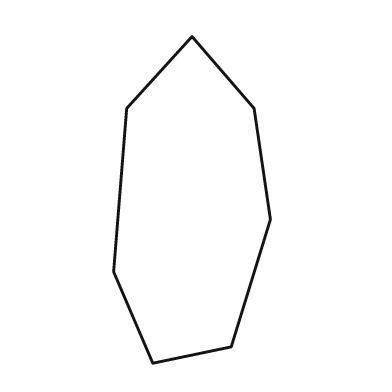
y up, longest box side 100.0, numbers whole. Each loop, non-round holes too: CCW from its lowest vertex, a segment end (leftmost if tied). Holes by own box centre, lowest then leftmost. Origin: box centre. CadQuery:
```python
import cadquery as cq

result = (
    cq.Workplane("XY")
    .moveTo(-12.0, -50.0)
    .lineTo(12.0, -45.0)
    .lineTo(24.0, -6.0)
    .lineTo(19.0, 28.0)
    .lineTo(0.0, 50.0)
    .lineTo(-20.0, 28.0)
    .lineTo(-24.0, -22.0)
    .close()
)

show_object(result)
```